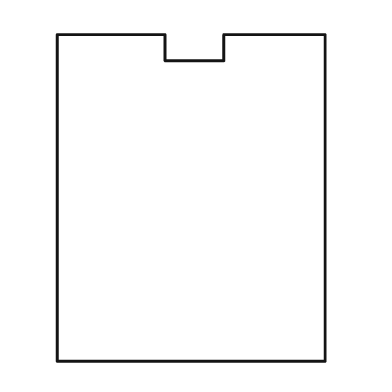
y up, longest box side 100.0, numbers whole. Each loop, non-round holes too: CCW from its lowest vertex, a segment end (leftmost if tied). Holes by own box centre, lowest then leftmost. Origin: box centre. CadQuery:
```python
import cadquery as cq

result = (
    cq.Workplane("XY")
    .moveTo(-41.0, -50.0)
    .lineTo(41.0, -50.0)
    .lineTo(41.0, 50.0)
    .lineTo(10.0, 50.0)
    .lineTo(10.0, 42.0)
    .lineTo(-8.0, 42.0)
    .lineTo(-8.0, 50.0)
    .lineTo(-41.0, 50.0)
    .close()
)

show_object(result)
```